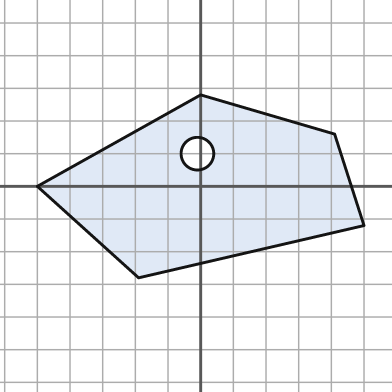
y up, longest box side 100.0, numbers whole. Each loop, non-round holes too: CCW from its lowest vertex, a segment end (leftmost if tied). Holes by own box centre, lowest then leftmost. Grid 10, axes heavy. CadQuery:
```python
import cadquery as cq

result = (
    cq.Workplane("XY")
    .moveTo(-19.0, -28.0)
    .lineTo(50.0, -12.0)
    .lineTo(41.0, 16.0)
    .lineTo(0.0, 28.0)
    .lineTo(-50.0, 0.0)
    .close()
    .moveTo(-1.0, 10.0)
    .circle(5.0)
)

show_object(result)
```